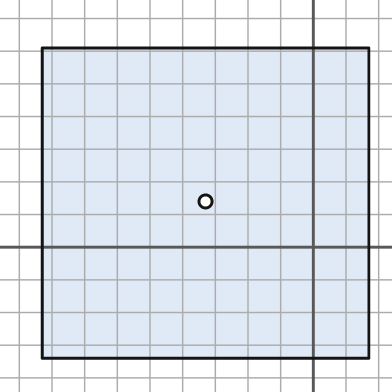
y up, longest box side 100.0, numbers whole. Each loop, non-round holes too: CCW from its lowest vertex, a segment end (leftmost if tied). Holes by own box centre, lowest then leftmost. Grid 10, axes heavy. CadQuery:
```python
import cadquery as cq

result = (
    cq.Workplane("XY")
    .moveTo(-83.0, -34.0)
    .lineTo(17.0, -34.0)
    .lineTo(17.0, 61.0)
    .lineTo(-83.0, 61.0)
    .close()
    .moveTo(-33.0, 14.0)
    .circle(2.0)
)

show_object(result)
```